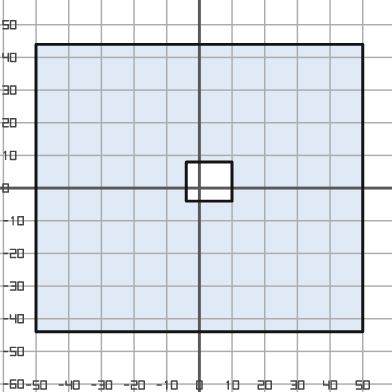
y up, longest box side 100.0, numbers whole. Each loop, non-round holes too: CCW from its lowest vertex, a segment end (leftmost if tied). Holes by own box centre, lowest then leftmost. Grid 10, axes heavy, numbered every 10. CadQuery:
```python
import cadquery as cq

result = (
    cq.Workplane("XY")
    .moveTo(-50.0, -44.0)
    .lineTo(50.0, -44.0)
    .lineTo(50.0, 44.0)
    .lineTo(-50.0, 44.0)
    .close()
    .moveTo(-4.0, -4.0)
    .lineTo(10.0, -4.0)
    .lineTo(10.0, 8.0)
    .lineTo(-4.0, 8.0)
    .close()
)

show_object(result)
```